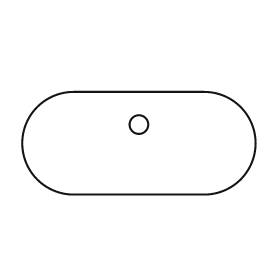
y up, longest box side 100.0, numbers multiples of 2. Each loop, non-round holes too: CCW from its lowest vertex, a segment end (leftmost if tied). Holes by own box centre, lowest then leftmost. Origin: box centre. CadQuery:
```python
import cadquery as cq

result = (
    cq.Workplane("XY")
    .moveTo(-28.0, -22.0)
    .lineTo(28.0, -22.0)
    .threePointArc((50.0, 0.0), (28.0, 22.0))
    .lineTo(-28.0, 22.0)
    .threePointArc((-50.0, 0.0), (-28.0, -22.0))
    .close()
    .moveTo(0.0, 8.0)
    .circle(4.0)
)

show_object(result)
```